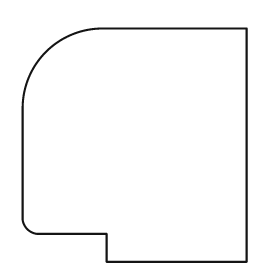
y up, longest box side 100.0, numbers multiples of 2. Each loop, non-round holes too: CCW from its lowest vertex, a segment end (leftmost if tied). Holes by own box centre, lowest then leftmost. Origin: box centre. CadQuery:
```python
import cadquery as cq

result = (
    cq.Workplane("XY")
    .moveTo(-12.0, -50.0)
    .lineTo(48.0, -50.0)
    .lineTo(48.0, 50.0)
    .lineTo(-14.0, 50.0)
    .threePointArc((-38.0, 40.0), (-48.0, 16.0))
    .lineTo(-48.0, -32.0)
    .threePointArc((-46.0, -36.0), (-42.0, -38.0))
    .lineTo(-12.0, -38.0)
    .close()
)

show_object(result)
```